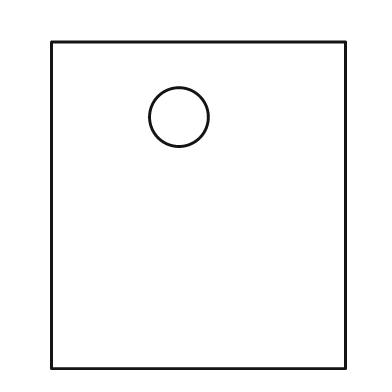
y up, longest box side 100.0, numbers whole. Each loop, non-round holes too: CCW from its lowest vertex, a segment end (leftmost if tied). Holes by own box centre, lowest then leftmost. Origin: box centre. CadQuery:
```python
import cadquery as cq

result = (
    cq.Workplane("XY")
    .moveTo(-45.0, -50.0)
    .lineTo(45.0, -50.0)
    .lineTo(45.0, 50.0)
    .lineTo(-45.0, 50.0)
    .close()
    .moveTo(-6.0, 27.0)
    .circle(9.0)
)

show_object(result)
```